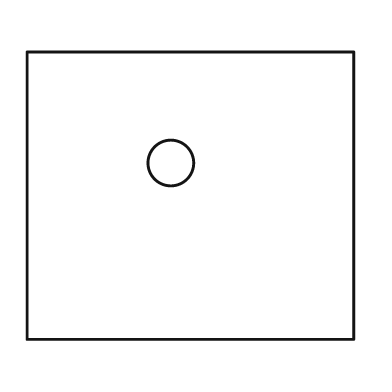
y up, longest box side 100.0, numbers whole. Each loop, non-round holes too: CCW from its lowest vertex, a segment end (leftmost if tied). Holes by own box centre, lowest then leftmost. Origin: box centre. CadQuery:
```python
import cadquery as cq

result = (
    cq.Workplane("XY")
    .moveTo(-50.0, -44.0)
    .lineTo(50.0, -44.0)
    .lineTo(50.0, 44.0)
    .lineTo(-50.0, 44.0)
    .close()
    .moveTo(-6.0, 10.0)
    .circle(7.0)
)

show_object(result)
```